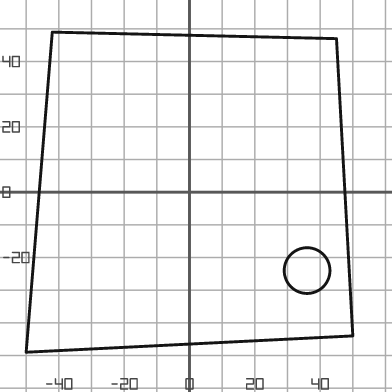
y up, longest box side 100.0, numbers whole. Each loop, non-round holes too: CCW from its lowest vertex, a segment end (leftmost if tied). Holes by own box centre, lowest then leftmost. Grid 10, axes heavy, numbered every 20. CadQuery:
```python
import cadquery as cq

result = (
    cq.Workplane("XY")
    .moveTo(-50.0, -49.0)
    .lineTo(50.0, -44.0)
    .lineTo(45.0, 47.0)
    .lineTo(-42.0, 49.0)
    .close()
    .moveTo(36.0, -24.0)
    .circle(7.0)
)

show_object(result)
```